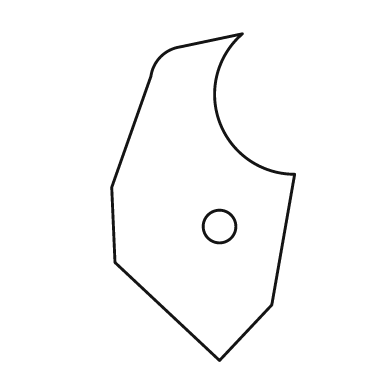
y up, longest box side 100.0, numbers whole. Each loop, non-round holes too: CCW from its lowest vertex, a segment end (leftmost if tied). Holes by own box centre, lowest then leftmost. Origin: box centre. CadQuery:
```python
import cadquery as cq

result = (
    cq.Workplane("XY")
    .moveTo(5.0, -50.0)
    .lineTo(21.0, -33.0)
    .lineTo(28.0, 7.0)
    .threePointArc((5.0, 23.0), (12.0, 50.0))
    .lineTo(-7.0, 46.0)
    .threePointArc((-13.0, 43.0), (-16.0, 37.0))
    .lineTo(-28.0, 3.0)
    .lineTo(-27.0, -20.0)
    .close()
    .moveTo(5.0, -9.0)
    .circle(5.0)
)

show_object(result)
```